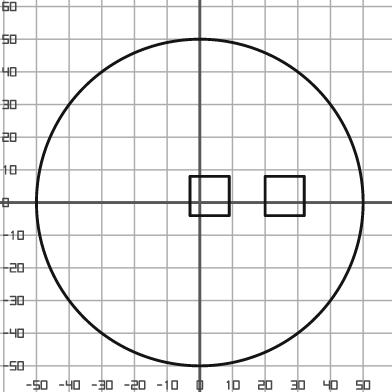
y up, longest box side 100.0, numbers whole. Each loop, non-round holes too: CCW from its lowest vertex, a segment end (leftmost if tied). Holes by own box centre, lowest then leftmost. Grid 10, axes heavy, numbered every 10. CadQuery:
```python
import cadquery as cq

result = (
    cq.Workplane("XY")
    .moveTo(0.0, 0.0)
    .circle(50.0)
    .moveTo(-3.0, -4.0)
    .lineTo(9.0, -4.0)
    .lineTo(9.0, 8.0)
    .lineTo(-3.0, 8.0)
    .close()
    .moveTo(20.0, -4.0)
    .lineTo(32.0, -4.0)
    .lineTo(32.0, 8.0)
    .lineTo(20.0, 8.0)
    .close()
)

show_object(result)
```